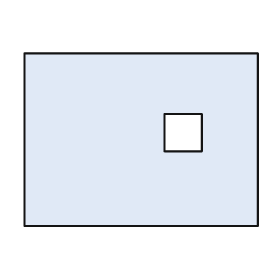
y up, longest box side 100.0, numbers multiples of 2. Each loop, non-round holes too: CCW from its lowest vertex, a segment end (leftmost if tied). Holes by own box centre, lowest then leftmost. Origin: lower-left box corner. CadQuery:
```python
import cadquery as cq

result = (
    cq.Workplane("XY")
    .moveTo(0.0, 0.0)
    .lineTo(100.0, 0.0)
    .lineTo(100.0, 74.0)
    .lineTo(0.0, 74.0)
    .close()
    .moveTo(60.0, 32.0)
    .lineTo(76.0, 32.0)
    .lineTo(76.0, 48.0)
    .lineTo(60.0, 48.0)
    .close()
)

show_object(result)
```